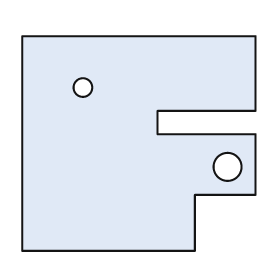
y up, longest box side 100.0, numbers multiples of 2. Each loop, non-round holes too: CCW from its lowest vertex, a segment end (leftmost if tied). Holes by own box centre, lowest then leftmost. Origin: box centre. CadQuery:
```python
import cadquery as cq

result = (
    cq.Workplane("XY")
    .moveTo(-50.0, -46.0)
    .lineTo(24.0, -46.0)
    .lineTo(24.0, -22.0)
    .lineTo(50.0, -22.0)
    .lineTo(50.0, 4.0)
    .lineTo(8.0, 4.0)
    .lineTo(8.0, 14.0)
    .lineTo(50.0, 14.0)
    .lineTo(50.0, 46.0)
    .lineTo(-50.0, 46.0)
    .close()
    .moveTo(38.0, -10.0)
    .circle(6.0)
    .moveTo(-24.0, 24.0)
    .circle(4.0)
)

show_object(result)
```